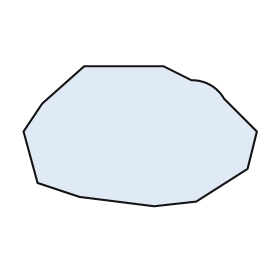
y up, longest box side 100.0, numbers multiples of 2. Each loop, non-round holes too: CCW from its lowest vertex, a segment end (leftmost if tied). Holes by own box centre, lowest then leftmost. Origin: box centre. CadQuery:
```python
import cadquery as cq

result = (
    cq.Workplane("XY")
    .moveTo(6.0, -30.0)
    .lineTo(24.0, -28.0)
    .lineTo(46.0, -14.0)
    .lineTo(50.0, 2.0)
    .lineTo(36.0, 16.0)
    .threePointArc((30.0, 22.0), (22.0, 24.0))
    .lineTo(10.0, 30.0)
    .lineTo(-24.0, 30.0)
    .lineTo(-42.0, 14.0)
    .lineTo(-50.0, 2.0)
    .lineTo(-44.0, -20.0)
    .lineTo(-26.0, -26.0)
    .close()
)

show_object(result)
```